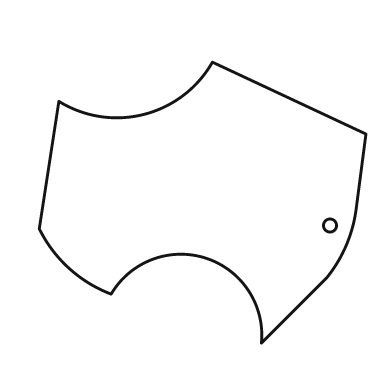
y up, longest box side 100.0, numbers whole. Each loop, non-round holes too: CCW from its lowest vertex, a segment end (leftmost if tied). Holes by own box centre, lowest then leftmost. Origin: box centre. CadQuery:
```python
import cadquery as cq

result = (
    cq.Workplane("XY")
    .moveTo(18.0, -43.0)
    .lineTo(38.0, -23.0)
    .threePointArc((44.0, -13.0), (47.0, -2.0))
    .lineTo(50.0, 21.0)
    .lineTo(3.0, 43.0)
    .threePointArc((-18.0, 27.0), (-44.0, 31.0))
    .lineTo(-50.0, -8.0)
    .threePointArc((-41.0, -20.0), (-28.0, -28.0))
    .threePointArc((1.0, -17.0), (18.0, -43.0))
    .close()
    .moveTo(39.0, -7.0)
    .circle(2.0)
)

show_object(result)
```